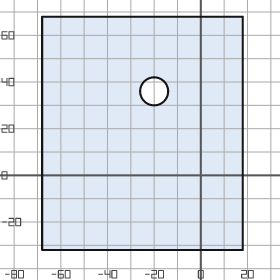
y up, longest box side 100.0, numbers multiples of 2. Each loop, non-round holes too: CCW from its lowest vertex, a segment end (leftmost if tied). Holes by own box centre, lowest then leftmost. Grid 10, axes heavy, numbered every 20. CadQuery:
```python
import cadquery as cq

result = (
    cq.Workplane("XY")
    .moveTo(-68.0, -32.0)
    .lineTo(18.0, -32.0)
    .lineTo(18.0, 68.0)
    .lineTo(-68.0, 68.0)
    .close()
    .moveTo(-20.0, 36.0)
    .circle(6.0)
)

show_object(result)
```